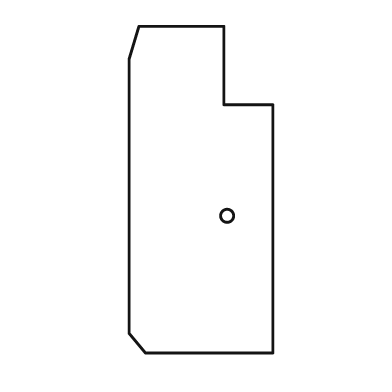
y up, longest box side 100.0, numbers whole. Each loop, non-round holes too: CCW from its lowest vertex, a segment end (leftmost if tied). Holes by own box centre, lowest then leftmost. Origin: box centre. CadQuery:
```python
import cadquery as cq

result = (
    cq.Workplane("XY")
    .moveTo(-17.0, -50.0)
    .lineTo(22.0, -50.0)
    .lineTo(22.0, 26.0)
    .lineTo(7.0, 26.0)
    .lineTo(7.0, 50.0)
    .lineTo(-19.0, 50.0)
    .lineTo(-22.0, 40.0)
    .lineTo(-22.0, -44.0)
    .close()
    .moveTo(8.0, -8.0)
    .circle(2.0)
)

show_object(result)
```